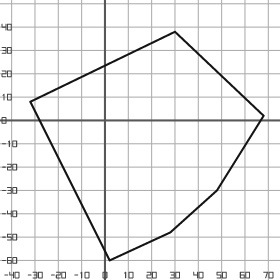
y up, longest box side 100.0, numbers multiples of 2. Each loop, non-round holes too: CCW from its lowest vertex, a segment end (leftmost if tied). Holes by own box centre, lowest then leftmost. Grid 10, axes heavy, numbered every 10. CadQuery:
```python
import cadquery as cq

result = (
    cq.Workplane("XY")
    .moveTo(2.0, -60.0)
    .lineTo(28.0, -48.0)
    .lineTo(48.0, -30.0)
    .lineTo(68.0, 2.0)
    .lineTo(30.0, 38.0)
    .lineTo(-32.0, 8.0)
    .close()
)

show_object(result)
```